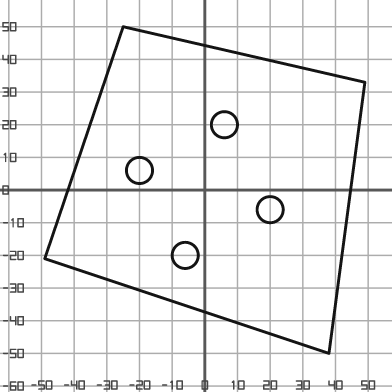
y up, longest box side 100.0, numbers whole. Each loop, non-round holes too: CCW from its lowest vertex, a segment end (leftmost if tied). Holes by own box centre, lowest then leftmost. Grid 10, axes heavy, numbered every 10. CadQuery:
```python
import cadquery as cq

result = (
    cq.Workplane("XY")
    .moveTo(38.0, -50.0)
    .lineTo(49.0, 33.0)
    .lineTo(-25.0, 50.0)
    .lineTo(-49.0, -21.0)
    .close()
    .moveTo(-6.0, -20.0)
    .circle(4.0)
    .moveTo(20.0, -6.0)
    .circle(4.0)
    .moveTo(-20.0, 6.0)
    .circle(4.0)
    .moveTo(6.0, 20.0)
    .circle(4.0)
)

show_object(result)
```